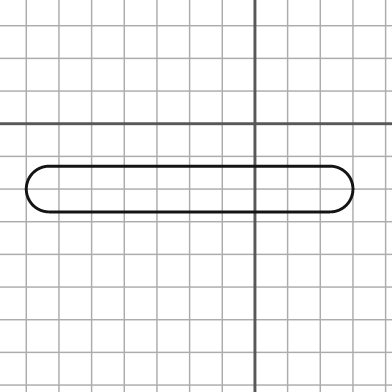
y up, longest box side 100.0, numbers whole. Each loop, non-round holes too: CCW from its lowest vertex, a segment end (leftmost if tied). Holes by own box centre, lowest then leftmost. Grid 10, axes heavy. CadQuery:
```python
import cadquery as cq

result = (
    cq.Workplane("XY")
    .moveTo(-63.0, -27.0)
    .lineTo(23.0, -27.0)
    .threePointArc((30.0, -20.0), (23.0, -13.0))
    .lineTo(-63.0, -13.0)
    .threePointArc((-70.0, -20.0), (-63.0, -27.0))
    .close()
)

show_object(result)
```